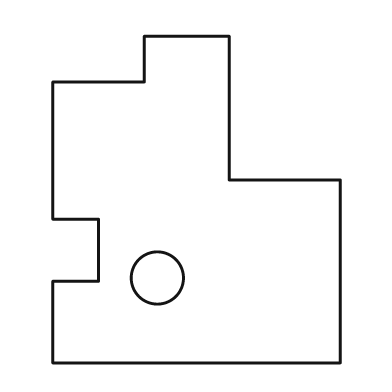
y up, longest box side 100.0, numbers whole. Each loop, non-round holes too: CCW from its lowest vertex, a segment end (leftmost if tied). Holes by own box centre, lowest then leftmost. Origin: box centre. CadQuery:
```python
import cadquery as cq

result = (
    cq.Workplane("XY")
    .moveTo(-44.0, -50.0)
    .lineTo(44.0, -50.0)
    .lineTo(44.0, 6.0)
    .lineTo(10.0, 6.0)
    .lineTo(10.0, 50.0)
    .lineTo(-16.0, 50.0)
    .lineTo(-16.0, 36.0)
    .lineTo(-44.0, 36.0)
    .lineTo(-44.0, -6.0)
    .lineTo(-30.0, -6.0)
    .lineTo(-30.0, -25.0)
    .lineTo(-44.0, -25.0)
    .close()
    .moveTo(-12.0, -24.0)
    .circle(8.0)
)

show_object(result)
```